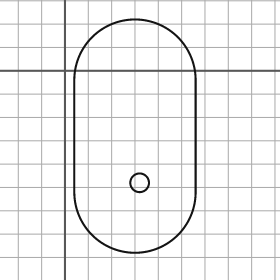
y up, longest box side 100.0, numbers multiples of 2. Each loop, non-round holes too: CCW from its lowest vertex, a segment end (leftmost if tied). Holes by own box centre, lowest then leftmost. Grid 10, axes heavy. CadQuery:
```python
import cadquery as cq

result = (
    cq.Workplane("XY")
    .moveTo(4.0, -52.0)
    .threePointArc((30.0, -78.0), (56.0, -52.0))
    .lineTo(56.0, -4.0)
    .threePointArc((30.0, 22.0), (4.0, -4.0))
    .close()
    .moveTo(32.0, -48.0)
    .circle(4.0)
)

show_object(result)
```